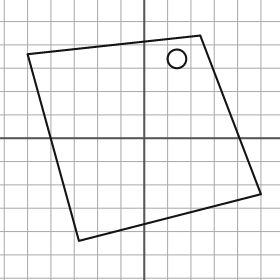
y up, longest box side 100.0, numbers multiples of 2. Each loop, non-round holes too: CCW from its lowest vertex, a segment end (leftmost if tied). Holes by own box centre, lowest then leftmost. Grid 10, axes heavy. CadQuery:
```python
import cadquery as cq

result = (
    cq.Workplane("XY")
    .moveTo(-28.0, -44.0)
    .lineTo(50.0, -24.0)
    .lineTo(24.0, 44.0)
    .lineTo(-50.0, 36.0)
    .close()
    .moveTo(14.0, 34.0)
    .circle(4.0)
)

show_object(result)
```